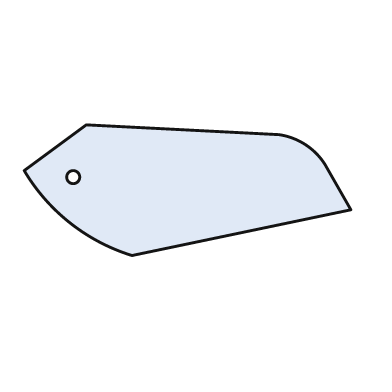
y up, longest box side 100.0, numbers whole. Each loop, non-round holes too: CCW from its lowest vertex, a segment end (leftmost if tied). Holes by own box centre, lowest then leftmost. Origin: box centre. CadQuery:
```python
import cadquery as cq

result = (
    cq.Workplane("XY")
    .moveTo(-17.0, -20.0)
    .lineTo(50.0, -6.0)
    .lineTo(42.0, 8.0)
    .threePointArc((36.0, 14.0), (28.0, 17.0))
    .lineTo(-31.0, 20.0)
    .lineTo(-50.0, 6.0)
    .threePointArc((-36.0, -10.0), (-17.0, -20.0))
    .close()
    .moveTo(-35.0, 4.0)
    .circle(2.0)
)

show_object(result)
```